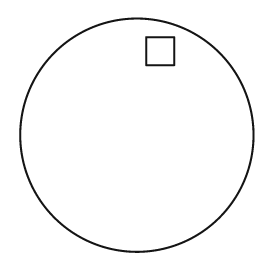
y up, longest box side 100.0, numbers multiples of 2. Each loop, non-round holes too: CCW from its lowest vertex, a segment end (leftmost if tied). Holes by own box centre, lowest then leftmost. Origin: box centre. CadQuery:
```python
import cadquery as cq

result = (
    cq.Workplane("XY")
    .moveTo(0.0, 0.0)
    .circle(50.0)
    .moveTo(4.0, 30.0)
    .lineTo(16.0, 30.0)
    .lineTo(16.0, 42.0)
    .lineTo(4.0, 42.0)
    .close()
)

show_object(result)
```